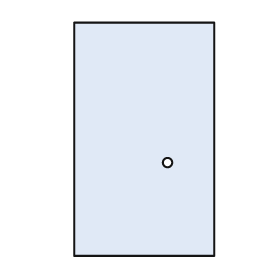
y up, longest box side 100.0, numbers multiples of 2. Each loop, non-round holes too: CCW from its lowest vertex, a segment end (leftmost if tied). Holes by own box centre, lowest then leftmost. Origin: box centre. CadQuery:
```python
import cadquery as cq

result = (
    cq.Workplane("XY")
    .moveTo(-30.0, -50.0)
    .lineTo(30.0, -50.0)
    .lineTo(30.0, 50.0)
    .lineTo(-30.0, 50.0)
    .close()
    .moveTo(10.0, -10.0)
    .circle(2.0)
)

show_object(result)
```